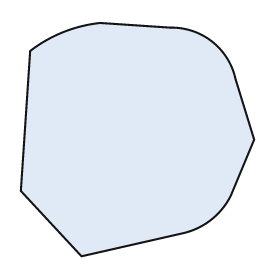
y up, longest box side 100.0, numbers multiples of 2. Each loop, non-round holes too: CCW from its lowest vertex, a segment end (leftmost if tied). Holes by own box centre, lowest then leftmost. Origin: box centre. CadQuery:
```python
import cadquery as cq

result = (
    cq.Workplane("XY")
    .moveTo(-24.0, -50.0)
    .lineTo(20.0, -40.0)
    .threePointArc((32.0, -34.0), (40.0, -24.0))
    .lineTo(50.0, 0.0)
    .lineTo(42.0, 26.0)
    .threePointArc((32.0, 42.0), (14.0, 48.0))
    .lineTo(-16.0, 50.0)
    .threePointArc((-32.0, 46.0), (-46.0, 38.0))
    .lineTo(-50.0, -22.0)
    .close()
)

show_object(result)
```